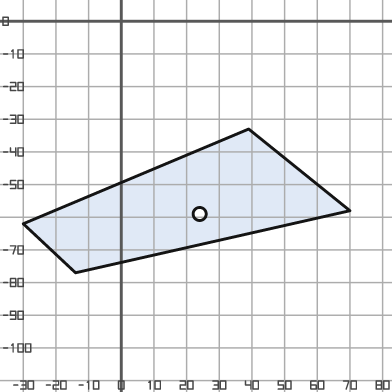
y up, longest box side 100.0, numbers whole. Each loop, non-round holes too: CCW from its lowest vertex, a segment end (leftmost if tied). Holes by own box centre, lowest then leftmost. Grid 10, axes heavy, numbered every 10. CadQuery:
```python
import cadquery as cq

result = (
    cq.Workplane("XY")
    .moveTo(-14.0, -77.0)
    .lineTo(70.0, -58.0)
    .lineTo(39.0, -33.0)
    .lineTo(-30.0, -62.0)
    .close()
    .moveTo(24.0, -59.0)
    .circle(2.0)
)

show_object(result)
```